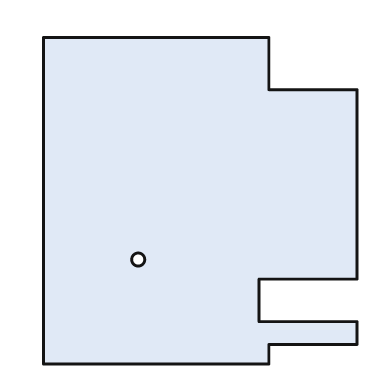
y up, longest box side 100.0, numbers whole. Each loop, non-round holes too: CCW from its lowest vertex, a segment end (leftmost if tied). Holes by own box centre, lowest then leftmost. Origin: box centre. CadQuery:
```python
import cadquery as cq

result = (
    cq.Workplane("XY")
    .moveTo(-48.0, -50.0)
    .lineTo(21.0, -50.0)
    .lineTo(21.0, -44.0)
    .lineTo(48.0, -44.0)
    .lineTo(48.0, -37.0)
    .lineTo(18.0, -37.0)
    .lineTo(18.0, -24.0)
    .lineTo(48.0, -24.0)
    .lineTo(48.0, 34.0)
    .lineTo(21.0, 34.0)
    .lineTo(21.0, 50.0)
    .lineTo(-48.0, 50.0)
    .close()
    .moveTo(-19.0, -18.0)
    .circle(2.0)
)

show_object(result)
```